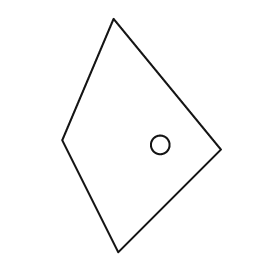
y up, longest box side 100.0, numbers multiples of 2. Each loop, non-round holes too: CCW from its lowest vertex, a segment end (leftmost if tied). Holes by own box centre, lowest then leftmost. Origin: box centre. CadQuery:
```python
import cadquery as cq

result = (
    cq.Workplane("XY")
    .moveTo(-10.0, -50.0)
    .lineTo(34.0, -6.0)
    .lineTo(-12.0, 50.0)
    .lineTo(-34.0, -2.0)
    .close()
    .moveTo(8.0, -4.0)
    .circle(4.0)
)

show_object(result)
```